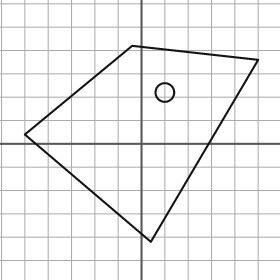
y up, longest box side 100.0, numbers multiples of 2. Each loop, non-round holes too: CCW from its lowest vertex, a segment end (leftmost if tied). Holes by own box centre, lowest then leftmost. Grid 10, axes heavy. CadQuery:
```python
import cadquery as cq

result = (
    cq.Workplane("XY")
    .moveTo(4.0, -42.0)
    .lineTo(50.0, 36.0)
    .lineTo(-4.0, 42.0)
    .lineTo(-50.0, 4.0)
    .close()
    .moveTo(10.0, 22.0)
    .circle(4.0)
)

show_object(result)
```